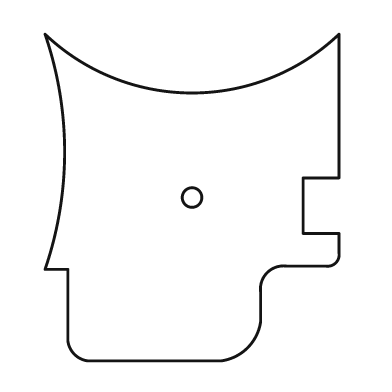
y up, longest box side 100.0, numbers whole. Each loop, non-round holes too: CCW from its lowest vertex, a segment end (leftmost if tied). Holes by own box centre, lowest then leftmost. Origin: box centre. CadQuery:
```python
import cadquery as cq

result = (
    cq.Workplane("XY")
    .moveTo(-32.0, -50.0)
    .lineTo(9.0, -50.0)
    .threePointArc((17.0, -46.0), (21.0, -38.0))
    .lineTo(21.0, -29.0)
    .threePointArc((23.0, -23.0), (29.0, -21.0))
    .lineTo(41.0, -21.0)
    .threePointArc((44.0, -20.0), (45.0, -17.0))
    .lineTo(45.0, -11.0)
    .lineTo(34.0, -11.0)
    .lineTo(34.0, 6.0)
    .lineTo(45.0, 6.0)
    .lineTo(45.0, 50.0)
    .threePointArc((0.0, 32.0), (-45.0, 50.0))
    .threePointArc((-39.0, 14.0), (-45.0, -22.0))
    .lineTo(-38.0, -22.0)
    .lineTo(-38.0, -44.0)
    .threePointArc((-36.0, -48.0), (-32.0, -50.0))
    .close()
    .moveTo(0.0, 0.0)
    .circle(3.0)
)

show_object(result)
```